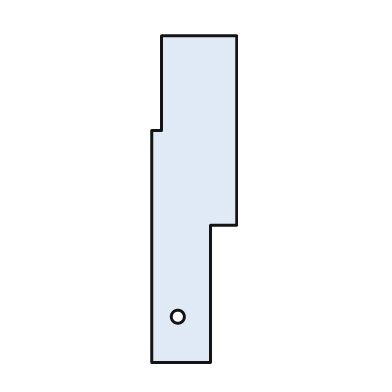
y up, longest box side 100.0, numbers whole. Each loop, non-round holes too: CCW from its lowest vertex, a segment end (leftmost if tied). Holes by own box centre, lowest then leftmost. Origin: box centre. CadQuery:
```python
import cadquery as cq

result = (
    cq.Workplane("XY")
    .moveTo(-13.0, -50.0)
    .lineTo(5.0, -50.0)
    .lineTo(5.0, -8.0)
    .lineTo(13.0, -8.0)
    .lineTo(13.0, 50.0)
    .lineTo(-10.0, 50.0)
    .lineTo(-10.0, 21.0)
    .lineTo(-13.0, 21.0)
    .close()
    .moveTo(-5.0, -36.0)
    .circle(2.0)
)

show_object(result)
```